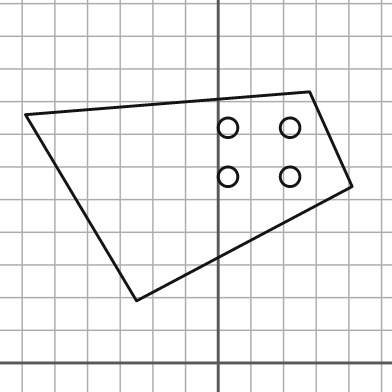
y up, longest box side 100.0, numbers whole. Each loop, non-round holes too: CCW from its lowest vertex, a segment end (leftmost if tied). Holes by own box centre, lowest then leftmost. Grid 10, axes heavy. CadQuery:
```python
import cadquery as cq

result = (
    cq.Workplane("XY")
    .moveTo(-25.0, 19.0)
    .lineTo(41.0, 54.0)
    .lineTo(28.0, 83.0)
    .lineTo(-59.0, 76.0)
    .close()
    .moveTo(3.0, 57.0)
    .circle(3.0)
    .moveTo(22.0, 57.0)
    .circle(3.0)
    .moveTo(3.0, 72.0)
    .circle(3.0)
    .moveTo(22.0, 72.0)
    .circle(3.0)
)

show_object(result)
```